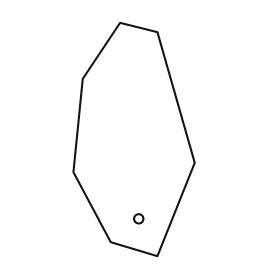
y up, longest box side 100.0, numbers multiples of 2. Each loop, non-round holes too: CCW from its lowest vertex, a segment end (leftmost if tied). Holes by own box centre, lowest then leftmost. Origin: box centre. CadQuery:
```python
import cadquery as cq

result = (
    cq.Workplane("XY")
    .moveTo(10.0, -50.0)
    .lineTo(26.0, -10.0)
    .lineTo(10.0, 46.0)
    .lineTo(-6.0, 50.0)
    .lineTo(-22.0, 26.0)
    .lineTo(-26.0, -14.0)
    .lineTo(-10.0, -44.0)
    .close()
    .moveTo(2.0, -34.0)
    .circle(2.0)
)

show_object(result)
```